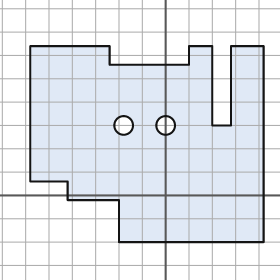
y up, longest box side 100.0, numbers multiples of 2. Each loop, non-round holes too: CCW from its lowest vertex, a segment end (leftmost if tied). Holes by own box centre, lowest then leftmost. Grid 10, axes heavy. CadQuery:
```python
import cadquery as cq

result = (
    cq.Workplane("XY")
    .moveTo(-20.0, -20.0)
    .lineTo(42.0, -20.0)
    .lineTo(42.0, 64.0)
    .lineTo(28.0, 64.0)
    .lineTo(28.0, 30.0)
    .lineTo(20.0, 30.0)
    .lineTo(20.0, 64.0)
    .lineTo(10.0, 64.0)
    .lineTo(10.0, 56.0)
    .lineTo(-24.0, 56.0)
    .lineTo(-24.0, 64.0)
    .lineTo(-58.0, 64.0)
    .lineTo(-58.0, 6.0)
    .lineTo(-42.0, 6.0)
    .lineTo(-42.0, -2.0)
    .lineTo(-20.0, -2.0)
    .close()
    .moveTo(-18.0, 30.0)
    .circle(4.0)
    .moveTo(0.0, 30.0)
    .circle(4.0)
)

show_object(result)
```